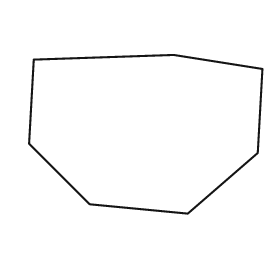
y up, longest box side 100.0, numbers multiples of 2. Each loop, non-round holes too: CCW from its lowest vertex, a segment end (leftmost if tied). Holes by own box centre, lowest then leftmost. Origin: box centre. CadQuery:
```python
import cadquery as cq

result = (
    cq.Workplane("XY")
    .moveTo(18.0, -34.0)
    .lineTo(48.0, -8.0)
    .lineTo(50.0, 28.0)
    .lineTo(12.0, 34.0)
    .lineTo(-48.0, 32.0)
    .lineTo(-50.0, -4.0)
    .lineTo(-24.0, -30.0)
    .close()
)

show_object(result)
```